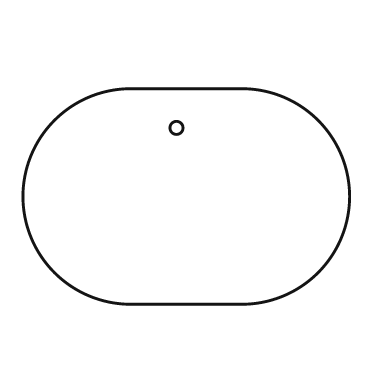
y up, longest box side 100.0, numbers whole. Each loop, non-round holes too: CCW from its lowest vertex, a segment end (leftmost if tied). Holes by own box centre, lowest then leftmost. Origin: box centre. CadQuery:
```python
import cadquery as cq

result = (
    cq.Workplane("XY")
    .moveTo(-17.0, -33.0)
    .lineTo(17.0, -33.0)
    .threePointArc((50.0, 0.0), (17.0, 33.0))
    .lineTo(-17.0, 33.0)
    .threePointArc((-50.0, 0.0), (-17.0, -33.0))
    .close()
    .moveTo(-3.0, 21.0)
    .circle(2.0)
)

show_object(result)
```